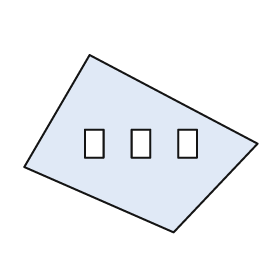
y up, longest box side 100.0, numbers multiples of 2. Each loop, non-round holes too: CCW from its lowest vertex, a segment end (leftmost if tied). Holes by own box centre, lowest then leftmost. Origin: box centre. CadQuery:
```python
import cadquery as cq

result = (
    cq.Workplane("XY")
    .moveTo(14.0, -38.0)
    .lineTo(50.0, 0.0)
    .lineTo(-22.0, 38.0)
    .lineTo(-50.0, -10.0)
    .close()
    .moveTo(-24.0, -6.0)
    .lineTo(-16.0, -6.0)
    .lineTo(-16.0, 6.0)
    .lineTo(-24.0, 6.0)
    .close()
    .moveTo(-4.0, -6.0)
    .lineTo(4.0, -6.0)
    .lineTo(4.0, 6.0)
    .lineTo(-4.0, 6.0)
    .close()
    .moveTo(16.0, -6.0)
    .lineTo(24.0, -6.0)
    .lineTo(24.0, 6.0)
    .lineTo(16.0, 6.0)
    .close()
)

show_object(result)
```